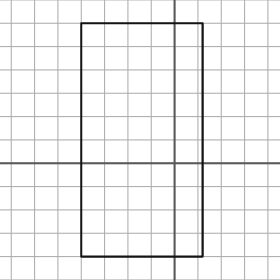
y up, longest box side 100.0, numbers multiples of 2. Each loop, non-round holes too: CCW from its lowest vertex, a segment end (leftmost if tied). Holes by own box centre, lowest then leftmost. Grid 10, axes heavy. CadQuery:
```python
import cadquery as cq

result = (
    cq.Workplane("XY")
    .moveTo(-40.0, -40.0)
    .lineTo(12.0, -40.0)
    .lineTo(12.0, 60.0)
    .lineTo(-40.0, 60.0)
    .close()
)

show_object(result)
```